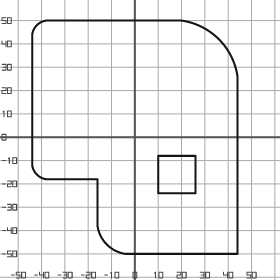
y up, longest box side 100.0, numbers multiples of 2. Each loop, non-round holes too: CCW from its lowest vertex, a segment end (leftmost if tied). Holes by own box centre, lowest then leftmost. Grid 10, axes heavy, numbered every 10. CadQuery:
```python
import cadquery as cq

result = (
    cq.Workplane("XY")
    .moveTo(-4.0, -50.0)
    .lineTo(44.0, -50.0)
    .lineTo(44.0, 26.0)
    .threePointArc((36.0, 42.0), (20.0, 50.0))
    .lineTo(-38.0, 50.0)
    .threePointArc((-42.0, 48.0), (-44.0, 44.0))
    .lineTo(-44.0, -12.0)
    .threePointArc((-42.0, -16.0), (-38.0, -18.0))
    .lineTo(-16.0, -18.0)
    .lineTo(-16.0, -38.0)
    .threePointArc((-12.0, -46.0), (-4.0, -50.0))
    .close()
    .moveTo(10.0, -24.0)
    .lineTo(26.0, -24.0)
    .lineTo(26.0, -8.0)
    .lineTo(10.0, -8.0)
    .close()
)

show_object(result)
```